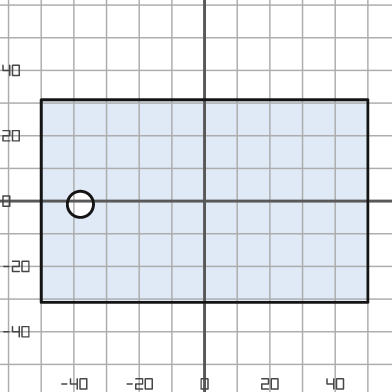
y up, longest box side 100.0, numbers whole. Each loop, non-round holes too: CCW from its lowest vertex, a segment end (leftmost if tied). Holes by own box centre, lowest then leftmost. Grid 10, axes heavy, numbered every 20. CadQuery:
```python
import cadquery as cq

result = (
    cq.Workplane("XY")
    .moveTo(-50.0, -31.0)
    .lineTo(50.0, -31.0)
    .lineTo(50.0, 31.0)
    .lineTo(-50.0, 31.0)
    .close()
    .moveTo(-38.0, -1.0)
    .circle(4.0)
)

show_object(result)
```